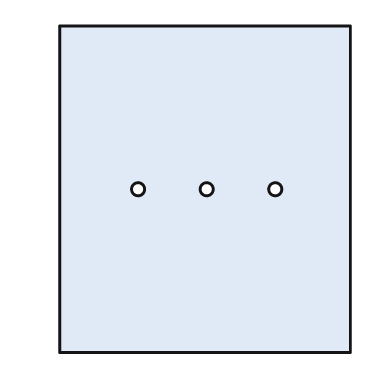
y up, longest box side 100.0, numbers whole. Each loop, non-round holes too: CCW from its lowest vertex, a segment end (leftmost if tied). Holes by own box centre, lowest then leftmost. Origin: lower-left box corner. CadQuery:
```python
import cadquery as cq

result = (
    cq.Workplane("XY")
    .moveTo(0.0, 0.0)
    .lineTo(89.0, 0.0)
    .lineTo(89.0, 100.0)
    .lineTo(0.0, 100.0)
    .close()
    .moveTo(24.0, 50.0)
    .circle(2.0)
    .moveTo(45.0, 50.0)
    .circle(2.0)
    .moveTo(66.0, 50.0)
    .circle(2.0)
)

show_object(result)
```